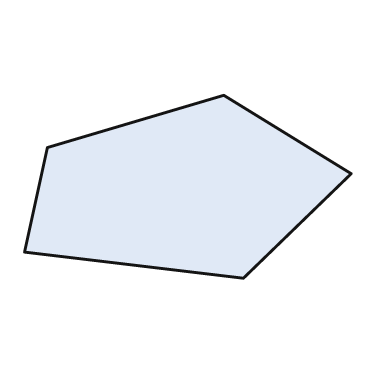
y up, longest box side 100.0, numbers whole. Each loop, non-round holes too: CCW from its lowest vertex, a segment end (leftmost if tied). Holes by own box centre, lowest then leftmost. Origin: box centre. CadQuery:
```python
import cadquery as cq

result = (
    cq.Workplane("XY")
    .moveTo(17.0, -28.0)
    .lineTo(50.0, 4.0)
    .lineTo(11.0, 28.0)
    .lineTo(-43.0, 12.0)
    .lineTo(-50.0, -20.0)
    .close()
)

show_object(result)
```